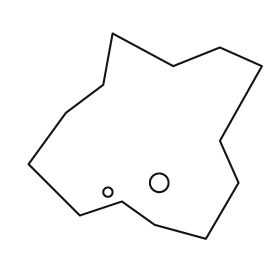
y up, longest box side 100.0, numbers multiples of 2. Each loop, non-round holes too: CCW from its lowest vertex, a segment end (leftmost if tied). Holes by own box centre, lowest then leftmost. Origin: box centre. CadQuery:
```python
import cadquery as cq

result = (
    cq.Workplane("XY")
    .moveTo(26.0, -44.0)
    .lineTo(40.0, -20.0)
    .lineTo(32.0, -2.0)
    .lineTo(50.0, 30.0)
    .lineTo(32.0, 38.0)
    .lineTo(12.0, 30.0)
    .lineTo(-14.0, 44.0)
    .lineTo(-18.0, 22.0)
    .lineTo(-34.0, 10.0)
    .lineTo(-50.0, -12.0)
    .lineTo(-28.0, -34.0)
    .lineTo(-10.0, -28.0)
    .lineTo(4.0, -38.0)
    .close()
    .moveTo(-16.0, -24.0)
    .circle(2.0)
    .moveTo(6.0, -20.0)
    .circle(4.0)
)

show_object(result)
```